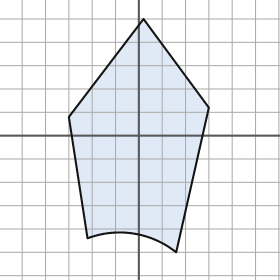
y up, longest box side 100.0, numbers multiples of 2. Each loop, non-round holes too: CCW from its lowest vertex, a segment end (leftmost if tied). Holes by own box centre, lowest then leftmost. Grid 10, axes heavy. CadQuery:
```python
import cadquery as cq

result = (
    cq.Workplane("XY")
    .moveTo(16.0, -50.0)
    .lineTo(30.0, 12.0)
    .lineTo(2.0, 50.0)
    .lineTo(-30.0, 8.0)
    .lineTo(-22.0, -44.0)
    .threePointArc((-2.0, -42.0), (16.0, -50.0))
    .close()
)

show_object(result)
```